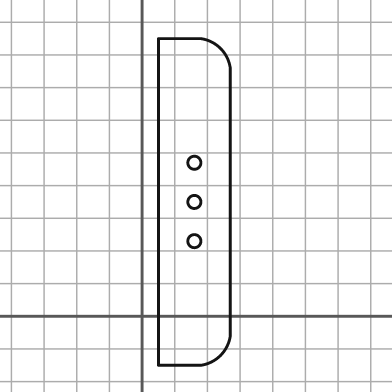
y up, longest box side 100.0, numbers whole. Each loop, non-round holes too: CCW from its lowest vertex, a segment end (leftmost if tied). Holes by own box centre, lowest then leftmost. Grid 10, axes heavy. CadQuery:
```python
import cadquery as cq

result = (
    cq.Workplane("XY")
    .moveTo(5.0, -15.0)
    .lineTo(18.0, -15.0)
    .threePointArc((24.0, -12.0), (27.0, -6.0))
    .lineTo(27.0, 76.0)
    .threePointArc((24.0, 82.0), (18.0, 85.0))
    .lineTo(5.0, 85.0)
    .close()
    .moveTo(16.0, 23.0)
    .circle(2.0)
    .moveTo(16.0, 35.0)
    .circle(2.0)
    .moveTo(16.0, 47.0)
    .circle(2.0)
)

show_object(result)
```